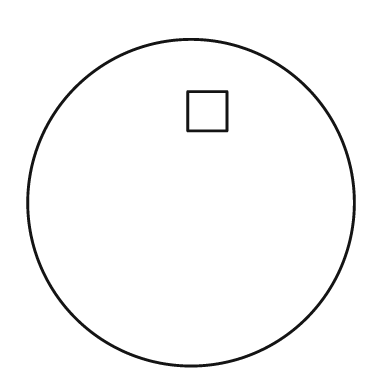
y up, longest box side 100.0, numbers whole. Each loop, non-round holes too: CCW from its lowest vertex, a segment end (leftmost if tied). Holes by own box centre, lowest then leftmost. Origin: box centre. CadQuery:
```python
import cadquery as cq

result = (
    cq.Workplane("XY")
    .moveTo(0.0, 0.0)
    .circle(50.0)
    .moveTo(-1.0, 22.0)
    .lineTo(11.0, 22.0)
    .lineTo(11.0, 34.0)
    .lineTo(-1.0, 34.0)
    .close()
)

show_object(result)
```